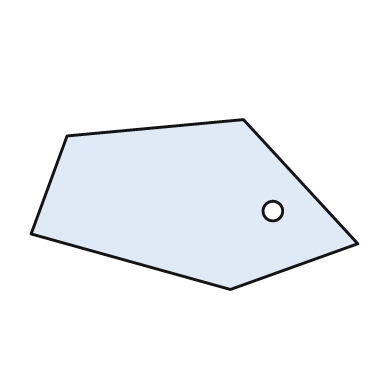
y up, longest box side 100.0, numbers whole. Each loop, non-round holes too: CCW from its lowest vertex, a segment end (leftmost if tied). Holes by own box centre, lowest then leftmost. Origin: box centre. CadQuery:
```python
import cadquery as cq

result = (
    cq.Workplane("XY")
    .moveTo(11.0, -26.0)
    .lineTo(50.0, -12.0)
    .lineTo(15.0, 26.0)
    .lineTo(-39.0, 21.0)
    .lineTo(-50.0, -9.0)
    .close()
    .moveTo(24.0, -2.0)
    .circle(3.0)
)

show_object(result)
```